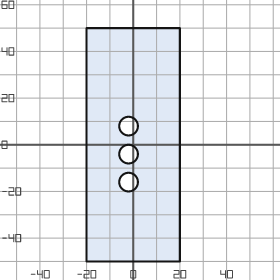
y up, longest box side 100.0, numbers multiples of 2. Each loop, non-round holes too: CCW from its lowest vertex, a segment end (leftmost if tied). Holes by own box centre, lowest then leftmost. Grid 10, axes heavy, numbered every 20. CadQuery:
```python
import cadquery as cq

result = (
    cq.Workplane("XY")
    .moveTo(-20.0, -50.0)
    .lineTo(20.0, -50.0)
    .lineTo(20.0, 50.0)
    .lineTo(-20.0, 50.0)
    .close()
    .moveTo(-2.0, -16.0)
    .circle(4.0)
    .moveTo(-2.0, -4.0)
    .circle(4.0)
    .moveTo(-2.0, 8.0)
    .circle(4.0)
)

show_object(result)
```